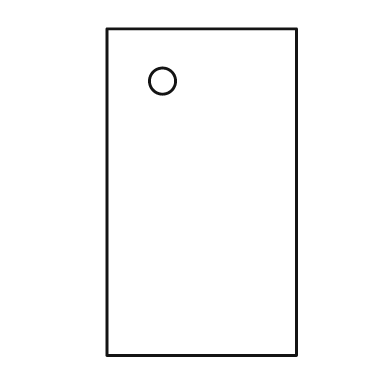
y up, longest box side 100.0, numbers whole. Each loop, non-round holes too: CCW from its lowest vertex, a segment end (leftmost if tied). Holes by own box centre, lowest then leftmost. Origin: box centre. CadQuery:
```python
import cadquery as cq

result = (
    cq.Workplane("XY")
    .moveTo(-29.0, -50.0)
    .lineTo(29.0, -50.0)
    .lineTo(29.0, 50.0)
    .lineTo(-29.0, 50.0)
    .close()
    .moveTo(-12.0, 34.0)
    .circle(4.0)
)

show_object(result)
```